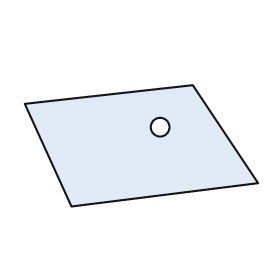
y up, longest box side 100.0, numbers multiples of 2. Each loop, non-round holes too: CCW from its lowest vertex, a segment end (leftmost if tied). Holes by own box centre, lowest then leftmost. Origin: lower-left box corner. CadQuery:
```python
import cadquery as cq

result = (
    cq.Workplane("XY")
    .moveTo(20.0, 0.0)
    .lineTo(100.0, 10.0)
    .lineTo(72.0, 52.0)
    .lineTo(0.0, 44.0)
    .close()
    .moveTo(58.0, 34.0)
    .circle(4.0)
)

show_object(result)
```